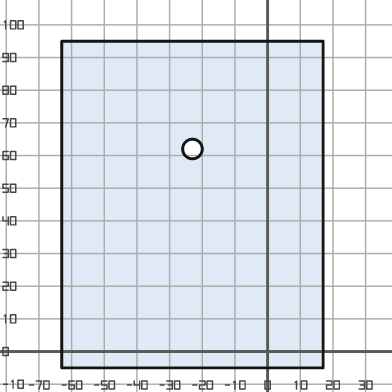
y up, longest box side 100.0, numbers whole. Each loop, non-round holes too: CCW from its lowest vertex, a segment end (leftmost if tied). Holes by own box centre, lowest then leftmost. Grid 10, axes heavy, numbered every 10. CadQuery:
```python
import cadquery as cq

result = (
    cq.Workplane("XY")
    .moveTo(-63.0, -5.0)
    .lineTo(17.0, -5.0)
    .lineTo(17.0, 95.0)
    .lineTo(-63.0, 95.0)
    .close()
    .moveTo(-23.0, 62.0)
    .circle(3.0)
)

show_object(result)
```